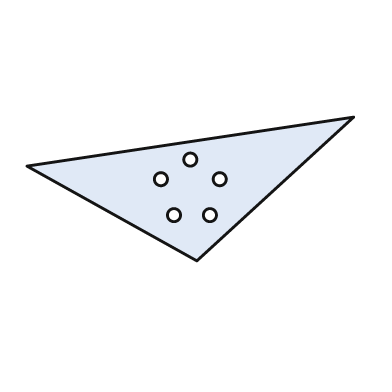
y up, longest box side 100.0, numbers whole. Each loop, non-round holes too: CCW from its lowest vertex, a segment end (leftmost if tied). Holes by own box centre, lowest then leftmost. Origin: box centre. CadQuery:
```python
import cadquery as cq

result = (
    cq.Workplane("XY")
    .moveTo(2.0, -22.0)
    .lineTo(50.0, 22.0)
    .lineTo(-50.0, 7.0)
    .close()
    .moveTo(-5.0, -8.0)
    .circle(2.0)
    .moveTo(6.0, -8.0)
    .circle(2.0)
    .moveTo(-9.0, 3.0)
    .circle(2.0)
    .moveTo(9.0, 3.0)
    .circle(2.0)
    .moveTo(0.0, 9.0)
    .circle(2.0)
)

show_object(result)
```